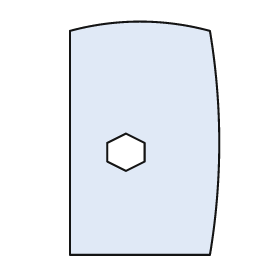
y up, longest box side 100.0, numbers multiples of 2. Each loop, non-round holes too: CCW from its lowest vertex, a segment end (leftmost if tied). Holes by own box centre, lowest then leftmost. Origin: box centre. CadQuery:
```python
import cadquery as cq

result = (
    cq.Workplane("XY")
    .moveTo(-32.0, -50.0)
    .lineTo(28.0, -50.0)
    .threePointArc((32.0, -2.0), (28.0, 46.0))
    .threePointArc((-2.0, 50.0), (-32.0, 46.0))
    .close()
    .moveTo(-8.0, -14.0)
    .lineTo(0.0, -10.0)
    .lineTo(0.0, -2.0)
    .lineTo(-8.0, 2.0)
    .lineTo(-16.0, -2.0)
    .lineTo(-16.0, -10.0)
    .close()
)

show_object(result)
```